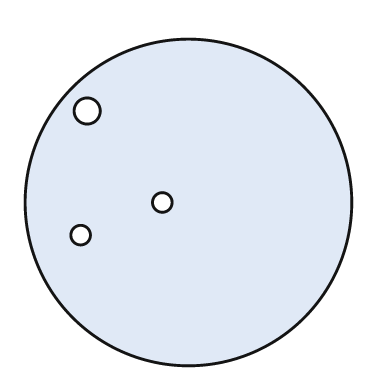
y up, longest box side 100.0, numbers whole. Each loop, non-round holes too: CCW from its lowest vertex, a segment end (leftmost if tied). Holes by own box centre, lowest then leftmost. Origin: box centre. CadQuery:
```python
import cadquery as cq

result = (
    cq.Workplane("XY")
    .moveTo(0.0, 0.0)
    .circle(50.0)
    .moveTo(-33.0, -10.0)
    .circle(3.0)
    .moveTo(-8.0, 0.0)
    .circle(3.0)
    .moveTo(-31.0, 28.0)
    .circle(4.0)
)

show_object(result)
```